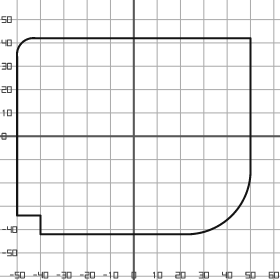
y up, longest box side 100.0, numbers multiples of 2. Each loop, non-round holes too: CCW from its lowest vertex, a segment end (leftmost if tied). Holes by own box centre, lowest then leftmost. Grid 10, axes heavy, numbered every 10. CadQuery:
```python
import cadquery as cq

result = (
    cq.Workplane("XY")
    .moveTo(-40.0, -42.0)
    .lineTo(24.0, -42.0)
    .threePointArc((42.0, -34.0), (50.0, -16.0))
    .lineTo(50.0, 42.0)
    .lineTo(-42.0, 42.0)
    .threePointArc((-48.0, 40.0), (-50.0, 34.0))
    .lineTo(-50.0, -34.0)
    .lineTo(-40.0, -34.0)
    .close()
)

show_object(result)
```